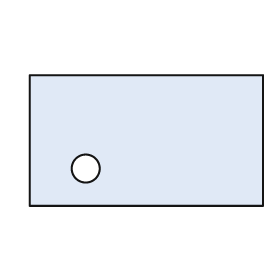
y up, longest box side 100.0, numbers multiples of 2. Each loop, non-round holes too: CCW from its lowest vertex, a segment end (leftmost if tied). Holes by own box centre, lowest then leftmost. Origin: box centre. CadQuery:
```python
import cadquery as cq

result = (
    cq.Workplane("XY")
    .moveTo(-50.0, -28.0)
    .lineTo(50.0, -28.0)
    .lineTo(50.0, 28.0)
    .lineTo(-50.0, 28.0)
    .close()
    .moveTo(-26.0, -12.0)
    .circle(6.0)
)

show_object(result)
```